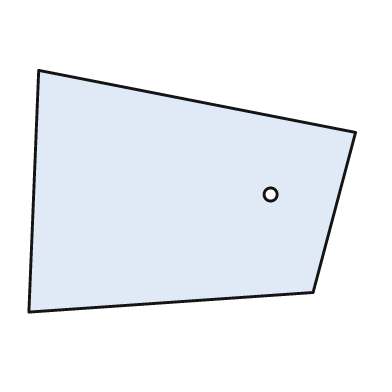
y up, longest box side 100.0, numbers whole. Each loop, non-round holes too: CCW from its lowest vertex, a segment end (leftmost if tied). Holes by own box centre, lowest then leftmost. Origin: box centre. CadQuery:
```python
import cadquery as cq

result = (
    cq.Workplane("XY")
    .moveTo(-50.0, -37.0)
    .lineTo(37.0, -31.0)
    .lineTo(50.0, 18.0)
    .lineTo(-47.0, 37.0)
    .close()
    .moveTo(24.0, -1.0)
    .circle(2.0)
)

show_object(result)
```